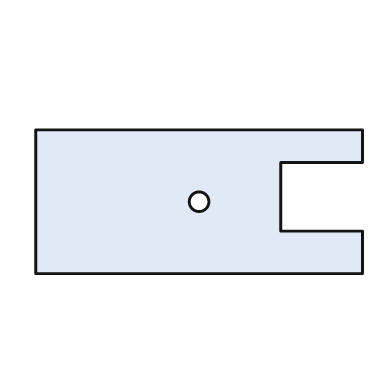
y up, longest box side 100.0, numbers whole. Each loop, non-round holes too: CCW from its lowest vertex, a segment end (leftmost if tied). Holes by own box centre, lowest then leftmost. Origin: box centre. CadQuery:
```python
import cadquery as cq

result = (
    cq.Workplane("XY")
    .moveTo(-50.0, -22.0)
    .lineTo(50.0, -22.0)
    .lineTo(50.0, -9.0)
    .lineTo(25.0, -9.0)
    .lineTo(25.0, 12.0)
    .lineTo(50.0, 12.0)
    .lineTo(50.0, 22.0)
    .lineTo(-50.0, 22.0)
    .close()
    .moveTo(0.0, 0.0)
    .circle(3.0)
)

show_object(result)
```